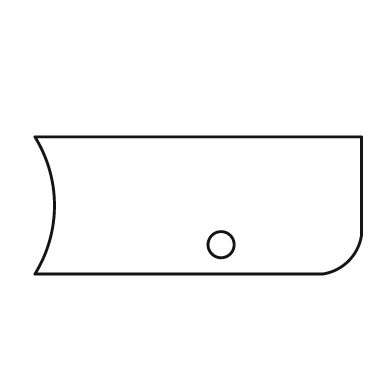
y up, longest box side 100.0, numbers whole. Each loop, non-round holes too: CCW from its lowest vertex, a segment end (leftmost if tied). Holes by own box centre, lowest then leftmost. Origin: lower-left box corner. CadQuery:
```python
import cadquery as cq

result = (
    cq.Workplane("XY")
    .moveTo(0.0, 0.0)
    .lineTo(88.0, 0.0)
    .threePointArc((96.0, 4.0), (100.0, 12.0))
    .lineTo(100.0, 42.0)
    .lineTo(0.0, 42.0)
    .threePointArc((6.0, 21.0), (0.0, 0.0))
    .close()
    .moveTo(57.0, 9.0)
    .circle(4.0)
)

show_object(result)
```